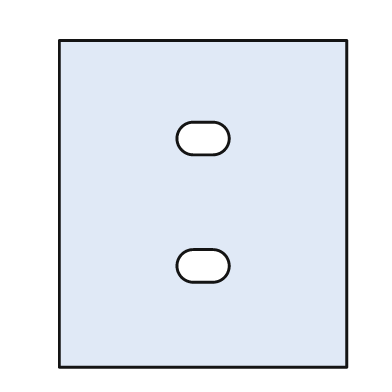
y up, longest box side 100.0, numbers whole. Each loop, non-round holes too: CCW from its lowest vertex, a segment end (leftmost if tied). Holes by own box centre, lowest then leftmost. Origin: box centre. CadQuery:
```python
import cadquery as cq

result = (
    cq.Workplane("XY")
    .moveTo(-44.0, -50.0)
    .lineTo(44.0, -50.0)
    .lineTo(44.0, 50.0)
    .lineTo(-44.0, 50.0)
    .close()
    .moveTo(-3.0, -24.0)
    .lineTo(3.0, -24.0)
    .threePointArc((8.0, -19.0), (3.0, -14.0))
    .lineTo(-3.0, -14.0)
    .threePointArc((-8.0, -19.0), (-3.0, -24.0))
    .close()
    .moveTo(-3.0, 15.0)
    .lineTo(3.0, 15.0)
    .threePointArc((8.0, 20.0), (3.0, 25.0))
    .lineTo(-3.0, 25.0)
    .threePointArc((-8.0, 20.0), (-3.0, 15.0))
    .close()
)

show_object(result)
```